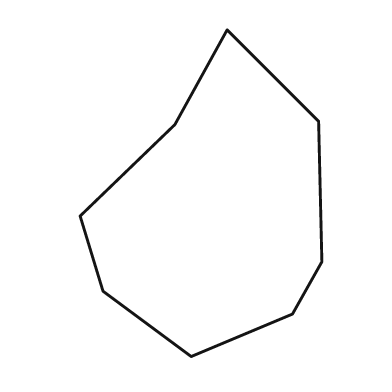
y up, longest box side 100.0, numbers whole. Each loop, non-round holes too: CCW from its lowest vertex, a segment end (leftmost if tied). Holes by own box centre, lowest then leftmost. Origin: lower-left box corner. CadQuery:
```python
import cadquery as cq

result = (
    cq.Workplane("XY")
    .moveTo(34.0, 0.0)
    .lineTo(65.0, 13.0)
    .lineTo(74.0, 29.0)
    .lineTo(73.0, 72.0)
    .lineTo(45.0, 100.0)
    .lineTo(29.0, 71.0)
    .lineTo(0.0, 43.0)
    .lineTo(7.0, 20.0)
    .close()
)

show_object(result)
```